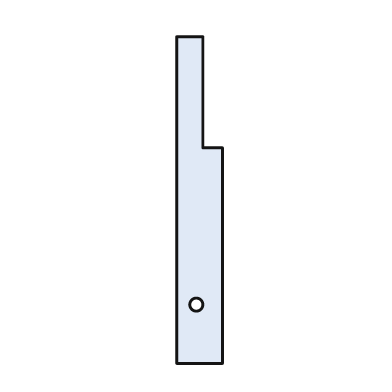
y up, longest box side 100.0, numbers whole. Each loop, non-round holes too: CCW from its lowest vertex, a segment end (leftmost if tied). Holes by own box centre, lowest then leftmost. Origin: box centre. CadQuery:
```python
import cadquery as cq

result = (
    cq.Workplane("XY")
    .moveTo(-7.0, -50.0)
    .lineTo(7.0, -50.0)
    .lineTo(7.0, 16.0)
    .lineTo(1.0, 16.0)
    .lineTo(1.0, 50.0)
    .lineTo(-7.0, 50.0)
    .close()
    .moveTo(-1.0, -32.0)
    .circle(2.0)
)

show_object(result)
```